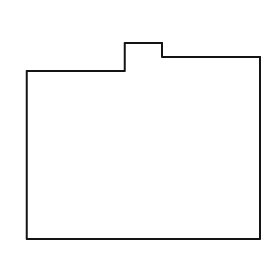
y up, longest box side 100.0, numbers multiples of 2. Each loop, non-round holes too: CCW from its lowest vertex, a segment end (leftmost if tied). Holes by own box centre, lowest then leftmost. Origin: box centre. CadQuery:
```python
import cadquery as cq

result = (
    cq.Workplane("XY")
    .moveTo(-50.0, -42.0)
    .lineTo(50.0, -42.0)
    .lineTo(50.0, 36.0)
    .lineTo(8.0, 36.0)
    .lineTo(8.0, 42.0)
    .lineTo(-8.0, 42.0)
    .lineTo(-8.0, 30.0)
    .lineTo(-50.0, 30.0)
    .close()
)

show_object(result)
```